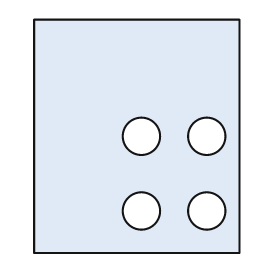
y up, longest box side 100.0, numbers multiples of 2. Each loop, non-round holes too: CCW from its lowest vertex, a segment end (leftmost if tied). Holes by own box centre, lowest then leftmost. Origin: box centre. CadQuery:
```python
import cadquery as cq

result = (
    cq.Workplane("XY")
    .moveTo(-44.0, -50.0)
    .lineTo(44.0, -50.0)
    .lineTo(44.0, 50.0)
    .lineTo(-44.0, 50.0)
    .close()
    .moveTo(2.0, -32.0)
    .circle(8.0)
    .moveTo(30.0, -32.0)
    .circle(8.0)
    .moveTo(2.0, 0.0)
    .circle(8.0)
    .moveTo(30.0, 0.0)
    .circle(8.0)
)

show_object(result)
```